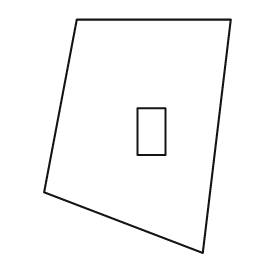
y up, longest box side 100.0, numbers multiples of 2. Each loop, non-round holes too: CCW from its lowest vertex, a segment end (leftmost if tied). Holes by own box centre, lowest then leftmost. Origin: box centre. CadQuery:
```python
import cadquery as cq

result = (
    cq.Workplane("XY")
    .moveTo(28.0, -50.0)
    .lineTo(40.0, 50.0)
    .lineTo(-26.0, 50.0)
    .lineTo(-40.0, -24.0)
    .close()
    .moveTo(0.0, -8.0)
    .lineTo(12.0, -8.0)
    .lineTo(12.0, 12.0)
    .lineTo(0.0, 12.0)
    .close()
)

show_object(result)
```